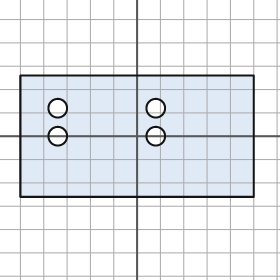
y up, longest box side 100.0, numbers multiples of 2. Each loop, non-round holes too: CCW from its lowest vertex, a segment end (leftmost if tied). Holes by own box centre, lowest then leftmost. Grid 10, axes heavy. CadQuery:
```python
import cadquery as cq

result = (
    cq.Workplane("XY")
    .moveTo(-50.0, -26.0)
    .lineTo(50.0, -26.0)
    .lineTo(50.0, 26.0)
    .lineTo(-50.0, 26.0)
    .close()
    .moveTo(-34.0, 0.0)
    .circle(4.0)
    .moveTo(8.0, 0.0)
    .circle(4.0)
    .moveTo(-34.0, 12.0)
    .circle(4.0)
    .moveTo(8.0, 12.0)
    .circle(4.0)
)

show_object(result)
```